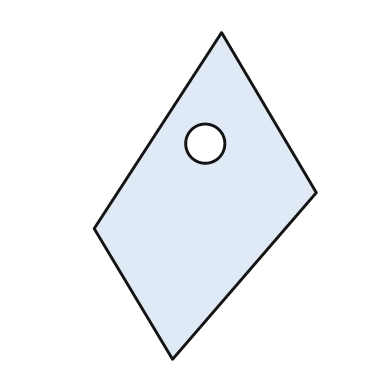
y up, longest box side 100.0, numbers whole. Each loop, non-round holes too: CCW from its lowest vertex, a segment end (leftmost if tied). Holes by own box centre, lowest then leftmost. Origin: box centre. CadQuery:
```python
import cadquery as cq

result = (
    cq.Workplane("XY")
    .moveTo(-10.0, -50.0)
    .lineTo(34.0, 1.0)
    .lineTo(5.0, 50.0)
    .lineTo(-34.0, -10.0)
    .close()
    .moveTo(0.0, 16.0)
    .circle(6.0)
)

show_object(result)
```